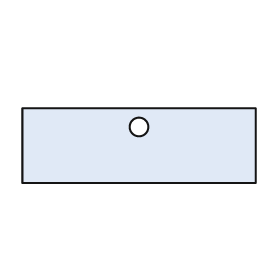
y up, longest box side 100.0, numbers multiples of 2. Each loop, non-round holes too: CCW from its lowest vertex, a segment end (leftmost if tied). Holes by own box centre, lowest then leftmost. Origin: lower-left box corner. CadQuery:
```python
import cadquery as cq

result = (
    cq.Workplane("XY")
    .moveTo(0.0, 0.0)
    .lineTo(100.0, 0.0)
    .lineTo(100.0, 32.0)
    .lineTo(0.0, 32.0)
    .close()
    .moveTo(50.0, 24.0)
    .circle(4.0)
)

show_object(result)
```